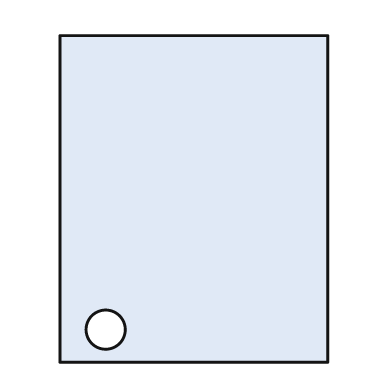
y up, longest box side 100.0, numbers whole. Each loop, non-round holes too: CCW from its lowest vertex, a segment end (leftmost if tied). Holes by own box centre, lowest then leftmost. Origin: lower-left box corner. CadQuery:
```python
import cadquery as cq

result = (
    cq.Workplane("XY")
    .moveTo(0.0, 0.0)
    .lineTo(82.0, 0.0)
    .lineTo(82.0, 100.0)
    .lineTo(0.0, 100.0)
    .close()
    .moveTo(14.0, 10.0)
    .circle(6.0)
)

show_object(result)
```